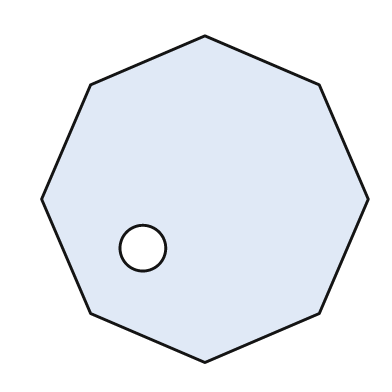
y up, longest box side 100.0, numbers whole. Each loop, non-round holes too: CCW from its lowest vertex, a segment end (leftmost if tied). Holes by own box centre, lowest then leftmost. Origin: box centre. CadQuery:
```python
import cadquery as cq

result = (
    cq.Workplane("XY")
    .moveTo(0.0, -50.0)
    .lineTo(35.0, -35.0)
    .lineTo(50.0, 0.0)
    .lineTo(35.0, 35.0)
    .lineTo(0.0, 50.0)
    .lineTo(-35.0, 35.0)
    .lineTo(-50.0, 0.0)
    .lineTo(-35.0, -35.0)
    .close()
    .moveTo(-19.0, -15.0)
    .circle(7.0)
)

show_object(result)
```